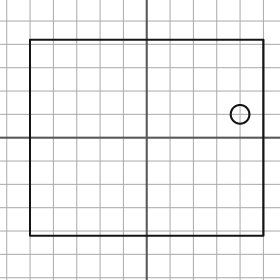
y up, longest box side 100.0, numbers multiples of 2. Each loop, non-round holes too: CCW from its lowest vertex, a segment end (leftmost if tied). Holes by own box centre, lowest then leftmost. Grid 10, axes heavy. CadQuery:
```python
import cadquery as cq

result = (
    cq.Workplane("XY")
    .moveTo(-50.0, -42.0)
    .lineTo(50.0, -42.0)
    .lineTo(50.0, 42.0)
    .lineTo(-50.0, 42.0)
    .close()
    .moveTo(40.0, 10.0)
    .circle(4.0)
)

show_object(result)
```